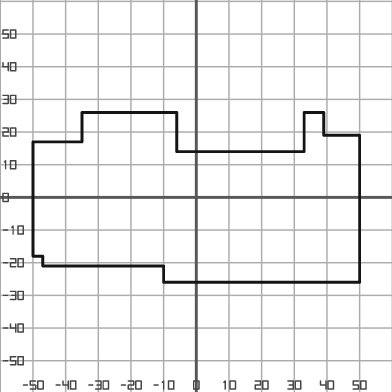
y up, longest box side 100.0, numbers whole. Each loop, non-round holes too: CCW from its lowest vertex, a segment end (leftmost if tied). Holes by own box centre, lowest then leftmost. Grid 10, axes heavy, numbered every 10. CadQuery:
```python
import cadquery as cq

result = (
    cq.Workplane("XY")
    .moveTo(-10.0, -26.0)
    .lineTo(50.0, -26.0)
    .lineTo(50.0, 19.0)
    .lineTo(39.0, 19.0)
    .lineTo(39.0, 26.0)
    .lineTo(33.0, 26.0)
    .lineTo(33.0, 14.0)
    .lineTo(-6.0, 14.0)
    .lineTo(-6.0, 26.0)
    .lineTo(-35.0, 26.0)
    .lineTo(-35.0, 17.0)
    .lineTo(-50.0, 17.0)
    .lineTo(-50.0, -18.0)
    .lineTo(-47.0, -18.0)
    .lineTo(-47.0, -21.0)
    .lineTo(-10.0, -21.0)
    .close()
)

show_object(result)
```